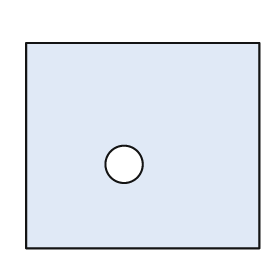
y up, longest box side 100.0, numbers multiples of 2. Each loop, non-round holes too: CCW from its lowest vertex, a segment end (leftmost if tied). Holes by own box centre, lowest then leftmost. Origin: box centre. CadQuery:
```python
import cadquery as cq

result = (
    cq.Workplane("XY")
    .moveTo(-50.0, -44.0)
    .lineTo(50.0, -44.0)
    .lineTo(50.0, 44.0)
    .lineTo(-50.0, 44.0)
    .close()
    .moveTo(-8.0, -8.0)
    .circle(8.0)
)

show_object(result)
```